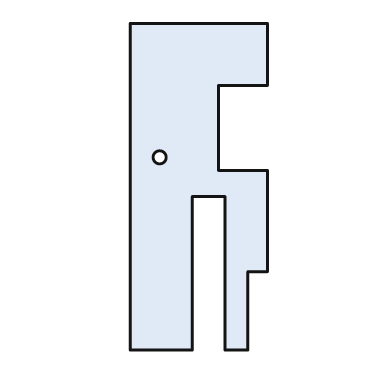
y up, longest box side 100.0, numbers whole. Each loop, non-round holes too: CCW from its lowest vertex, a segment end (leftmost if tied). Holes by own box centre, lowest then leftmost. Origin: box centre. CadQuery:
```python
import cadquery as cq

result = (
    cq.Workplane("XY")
    .moveTo(-21.0, -50.0)
    .lineTo(-2.0, -50.0)
    .lineTo(-2.0, -3.0)
    .lineTo(8.0, -3.0)
    .lineTo(8.0, -50.0)
    .lineTo(15.0, -50.0)
    .lineTo(15.0, -26.0)
    .lineTo(21.0, -26.0)
    .lineTo(21.0, 5.0)
    .lineTo(6.0, 5.0)
    .lineTo(6.0, 31.0)
    .lineTo(21.0, 31.0)
    .lineTo(21.0, 50.0)
    .lineTo(-21.0, 50.0)
    .close()
    .moveTo(-12.0, 9.0)
    .circle(2.0)
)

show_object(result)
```